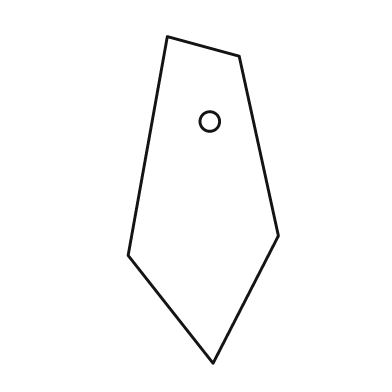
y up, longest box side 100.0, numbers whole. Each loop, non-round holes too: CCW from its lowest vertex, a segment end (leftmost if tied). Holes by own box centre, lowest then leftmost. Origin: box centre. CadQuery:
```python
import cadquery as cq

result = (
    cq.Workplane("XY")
    .moveTo(3.0, -50.0)
    .lineTo(23.0, -11.0)
    .lineTo(11.0, 44.0)
    .lineTo(-11.0, 50.0)
    .lineTo(-23.0, -17.0)
    .close()
    .moveTo(2.0, 24.0)
    .circle(3.0)
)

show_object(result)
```